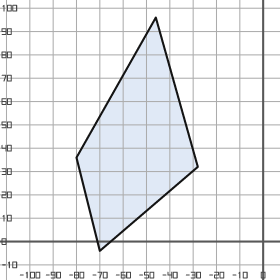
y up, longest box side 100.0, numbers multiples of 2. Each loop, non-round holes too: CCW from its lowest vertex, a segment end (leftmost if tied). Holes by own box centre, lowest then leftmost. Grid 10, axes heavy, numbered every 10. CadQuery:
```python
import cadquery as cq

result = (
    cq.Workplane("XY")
    .moveTo(-70.0, -4.0)
    .lineTo(-28.0, 32.0)
    .lineTo(-46.0, 96.0)
    .lineTo(-80.0, 36.0)
    .close()
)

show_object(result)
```